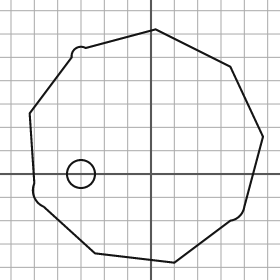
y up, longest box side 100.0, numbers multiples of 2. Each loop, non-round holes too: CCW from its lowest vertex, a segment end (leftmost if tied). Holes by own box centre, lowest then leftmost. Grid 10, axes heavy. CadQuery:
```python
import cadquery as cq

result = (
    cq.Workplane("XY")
    .moveTo(10.0, -38.0)
    .lineTo(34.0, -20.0)
    .threePointArc((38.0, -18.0), (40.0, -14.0))
    .lineTo(48.0, 16.0)
    .lineTo(34.0, 46.0)
    .lineTo(2.0, 62.0)
    .lineTo(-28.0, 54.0)
    .threePointArc((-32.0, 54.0), (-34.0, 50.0))
    .lineTo(-52.0, 26.0)
    .lineTo(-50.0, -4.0)
    .threePointArc((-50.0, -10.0), (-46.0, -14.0))
    .lineTo(-24.0, -34.0)
    .close()
    .moveTo(-30.0, 0.0)
    .circle(6.0)
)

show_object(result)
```